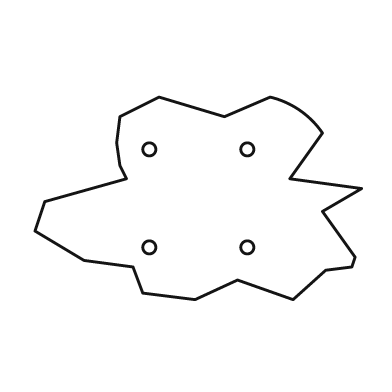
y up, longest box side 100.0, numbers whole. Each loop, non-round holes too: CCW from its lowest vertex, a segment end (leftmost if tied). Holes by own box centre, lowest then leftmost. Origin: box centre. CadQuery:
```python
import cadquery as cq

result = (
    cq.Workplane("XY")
    .moveTo(-1.0, -31.0)
    .lineTo(12.0, -25.0)
    .lineTo(29.0, -31.0)
    .lineTo(39.0, -22.0)
    .lineTo(47.0, -21.0)
    .lineTo(48.0, -18.0)
    .lineTo(38.0, -4.0)
    .lineTo(50.0, 3.0)
    .lineTo(28.0, 6.0)
    .lineTo(38.0, 20.0)
    .threePointArc((31.0, 27.0), (22.0, 31.0))
    .lineTo(8.0, 25.0)
    .lineTo(-12.0, 31.0)
    .lineTo(-24.0, 25.0)
    .lineTo(-25.0, 17.0)
    .lineTo(-24.0, 10.0)
    .lineTo(-22.0, 6.0)
    .lineTo(-47.0, -1.0)
    .lineTo(-50.0, -10.0)
    .lineTo(-35.0, -19.0)
    .lineTo(-20.0, -21.0)
    .lineTo(-17.0, -29.0)
    .close()
    .moveTo(-15.0, -15.0)
    .circle(2.0)
    .moveTo(15.0, -15.0)
    .circle(2.0)
    .moveTo(-15.0, 15.0)
    .circle(2.0)
    .moveTo(15.0, 15.0)
    .circle(2.0)
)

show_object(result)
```